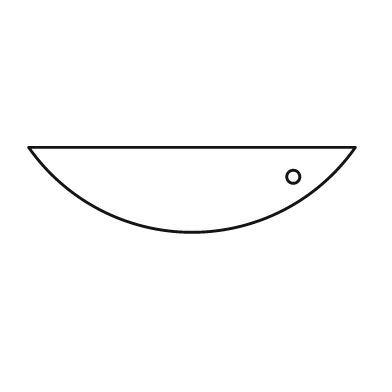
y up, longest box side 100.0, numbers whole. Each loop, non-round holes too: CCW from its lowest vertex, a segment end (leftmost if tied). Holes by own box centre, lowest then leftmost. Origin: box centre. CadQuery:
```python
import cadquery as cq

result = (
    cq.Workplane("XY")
    .moveTo(-50.0, 13.0)
    .threePointArc((0.0, -13.0), (50.0, 13.0))
    .close()
    .moveTo(31.0, 4.0)
    .circle(2.0)
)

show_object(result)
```